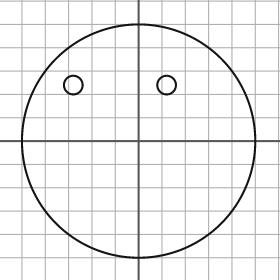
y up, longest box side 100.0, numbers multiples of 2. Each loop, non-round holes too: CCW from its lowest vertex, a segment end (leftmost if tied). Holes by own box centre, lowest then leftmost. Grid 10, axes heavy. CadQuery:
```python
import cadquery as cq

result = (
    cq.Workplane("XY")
    .moveTo(0.0, 0.0)
    .circle(50.0)
    .moveTo(-28.0, 24.0)
    .circle(4.0)
    .moveTo(12.0, 24.0)
    .circle(4.0)
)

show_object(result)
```